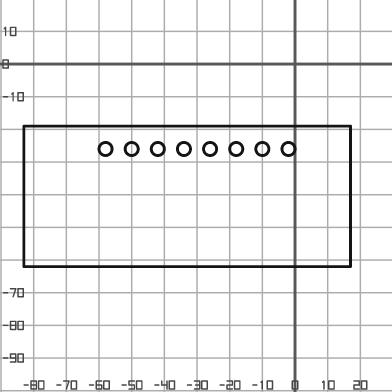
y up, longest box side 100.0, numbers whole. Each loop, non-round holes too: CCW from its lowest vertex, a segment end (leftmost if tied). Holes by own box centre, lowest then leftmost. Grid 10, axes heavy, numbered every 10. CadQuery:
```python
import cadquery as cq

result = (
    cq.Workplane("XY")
    .moveTo(-83.0, -62.0)
    .lineTo(17.0, -62.0)
    .lineTo(17.0, -19.0)
    .lineTo(-83.0, -19.0)
    .close()
    .moveTo(-58.0, -26.0)
    .circle(2.0)
    .moveTo(-50.0, -26.0)
    .circle(2.0)
    .moveTo(-42.0, -26.0)
    .circle(2.0)
    .moveTo(-34.0, -26.0)
    .circle(2.0)
    .moveTo(-26.0, -26.0)
    .circle(2.0)
    .moveTo(-18.0, -26.0)
    .circle(2.0)
    .moveTo(-10.0, -26.0)
    .circle(2.0)
    .moveTo(-2.0, -26.0)
    .circle(2.0)
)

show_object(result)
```